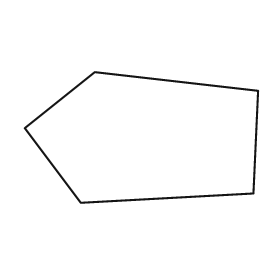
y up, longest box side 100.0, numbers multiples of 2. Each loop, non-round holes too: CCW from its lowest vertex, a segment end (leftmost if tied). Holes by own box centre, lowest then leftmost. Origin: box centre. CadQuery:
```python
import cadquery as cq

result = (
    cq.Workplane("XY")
    .moveTo(-26.0, -28.0)
    .lineTo(48.0, -24.0)
    .lineTo(50.0, 20.0)
    .lineTo(-20.0, 28.0)
    .lineTo(-50.0, 4.0)
    .close()
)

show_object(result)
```